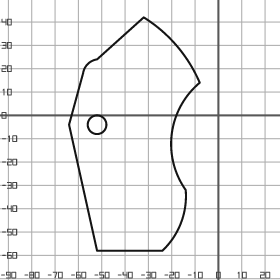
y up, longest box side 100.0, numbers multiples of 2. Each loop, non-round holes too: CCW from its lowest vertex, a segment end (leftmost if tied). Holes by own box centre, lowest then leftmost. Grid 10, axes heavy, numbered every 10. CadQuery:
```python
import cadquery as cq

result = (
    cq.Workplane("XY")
    .moveTo(-52.0, -58.0)
    .lineTo(-24.0, -58.0)
    .threePointArc((-16.0, -46.0), (-14.0, -32.0))
    .threePointArc((-20.0, -8.0), (-8.0, 14.0))
    .threePointArc((-18.0, 30.0), (-32.0, 42.0))
    .lineTo(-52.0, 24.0)
    .threePointArc((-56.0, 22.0), (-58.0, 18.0))
    .lineTo(-64.0, -4.0)
    .close()
    .moveTo(-52.0, -4.0)
    .circle(4.0)
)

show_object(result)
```